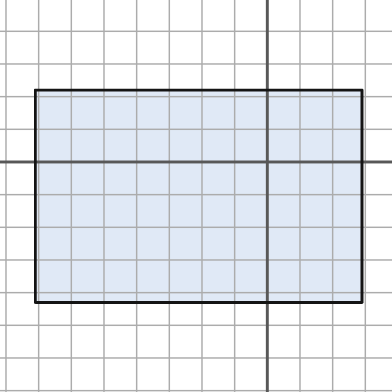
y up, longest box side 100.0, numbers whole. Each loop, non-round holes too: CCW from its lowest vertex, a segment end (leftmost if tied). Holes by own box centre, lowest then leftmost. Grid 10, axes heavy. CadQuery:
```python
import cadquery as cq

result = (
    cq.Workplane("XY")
    .moveTo(-71.0, -43.0)
    .lineTo(29.0, -43.0)
    .lineTo(29.0, 22.0)
    .lineTo(-71.0, 22.0)
    .close()
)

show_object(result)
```